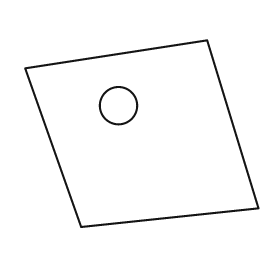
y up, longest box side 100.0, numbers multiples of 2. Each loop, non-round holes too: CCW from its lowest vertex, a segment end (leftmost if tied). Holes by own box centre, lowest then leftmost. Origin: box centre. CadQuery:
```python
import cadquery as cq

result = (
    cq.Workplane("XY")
    .moveTo(-26.0, -40.0)
    .lineTo(50.0, -32.0)
    .lineTo(28.0, 40.0)
    .lineTo(-50.0, 28.0)
    .close()
    .moveTo(-10.0, 12.0)
    .circle(8.0)
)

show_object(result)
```